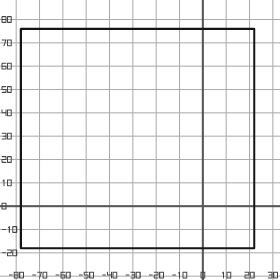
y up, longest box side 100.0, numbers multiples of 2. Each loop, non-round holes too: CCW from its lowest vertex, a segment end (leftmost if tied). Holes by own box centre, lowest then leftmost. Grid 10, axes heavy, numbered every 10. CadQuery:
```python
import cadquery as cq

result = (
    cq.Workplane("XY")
    .moveTo(-78.0, -18.0)
    .lineTo(22.0, -18.0)
    .lineTo(22.0, 76.0)
    .lineTo(-78.0, 76.0)
    .close()
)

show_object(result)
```